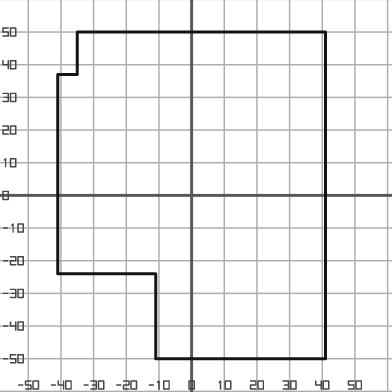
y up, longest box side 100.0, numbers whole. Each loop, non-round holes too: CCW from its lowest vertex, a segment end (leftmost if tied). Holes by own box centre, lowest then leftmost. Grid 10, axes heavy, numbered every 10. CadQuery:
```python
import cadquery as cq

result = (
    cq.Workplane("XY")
    .moveTo(-11.0, -50.0)
    .lineTo(41.0, -50.0)
    .lineTo(41.0, 50.0)
    .lineTo(-35.0, 50.0)
    .lineTo(-35.0, 37.0)
    .lineTo(-41.0, 37.0)
    .lineTo(-41.0, -24.0)
    .lineTo(-11.0, -24.0)
    .close()
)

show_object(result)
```